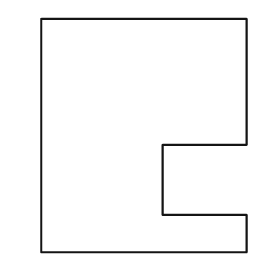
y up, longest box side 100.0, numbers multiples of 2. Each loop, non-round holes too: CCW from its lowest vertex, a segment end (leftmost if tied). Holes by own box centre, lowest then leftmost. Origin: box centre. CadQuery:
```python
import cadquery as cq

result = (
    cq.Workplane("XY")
    .moveTo(-44.0, -50.0)
    .lineTo(44.0, -50.0)
    .lineTo(44.0, -34.0)
    .lineTo(8.0, -34.0)
    .lineTo(8.0, -4.0)
    .lineTo(44.0, -4.0)
    .lineTo(44.0, 50.0)
    .lineTo(-44.0, 50.0)
    .close()
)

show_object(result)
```